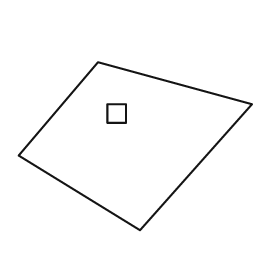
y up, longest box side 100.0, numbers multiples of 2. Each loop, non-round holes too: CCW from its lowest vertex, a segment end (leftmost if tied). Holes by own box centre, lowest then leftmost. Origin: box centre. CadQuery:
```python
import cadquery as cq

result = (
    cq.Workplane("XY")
    .moveTo(2.0, -36.0)
    .lineTo(50.0, 18.0)
    .lineTo(-16.0, 36.0)
    .lineTo(-50.0, -4.0)
    .close()
    .moveTo(-12.0, 10.0)
    .lineTo(-4.0, 10.0)
    .lineTo(-4.0, 18.0)
    .lineTo(-12.0, 18.0)
    .close()
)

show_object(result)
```